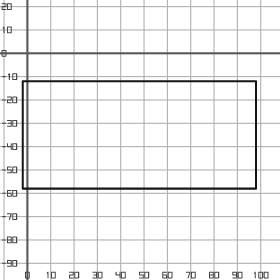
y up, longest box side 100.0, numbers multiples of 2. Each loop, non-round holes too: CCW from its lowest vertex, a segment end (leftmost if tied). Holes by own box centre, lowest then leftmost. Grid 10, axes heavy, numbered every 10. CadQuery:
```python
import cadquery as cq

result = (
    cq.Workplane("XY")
    .moveTo(-2.0, -58.0)
    .lineTo(98.0, -58.0)
    .lineTo(98.0, -12.0)
    .lineTo(-2.0, -12.0)
    .close()
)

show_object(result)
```